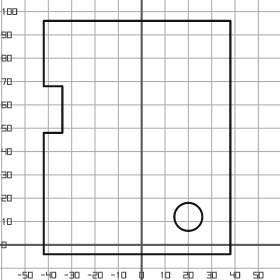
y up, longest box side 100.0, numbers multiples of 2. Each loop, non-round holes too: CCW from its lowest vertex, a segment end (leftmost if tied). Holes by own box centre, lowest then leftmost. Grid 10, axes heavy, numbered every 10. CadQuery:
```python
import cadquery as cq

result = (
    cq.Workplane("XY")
    .moveTo(-42.0, -4.0)
    .lineTo(38.0, -4.0)
    .lineTo(38.0, 96.0)
    .lineTo(-42.0, 96.0)
    .lineTo(-42.0, 68.0)
    .lineTo(-34.0, 68.0)
    .lineTo(-34.0, 48.0)
    .lineTo(-42.0, 48.0)
    .close()
    .moveTo(20.0, 12.0)
    .circle(6.0)
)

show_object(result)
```